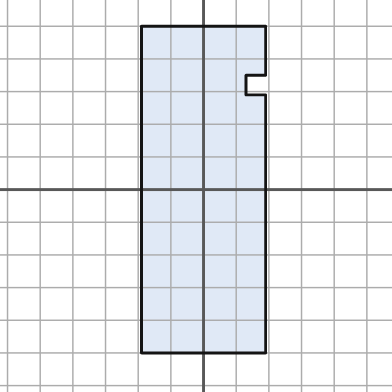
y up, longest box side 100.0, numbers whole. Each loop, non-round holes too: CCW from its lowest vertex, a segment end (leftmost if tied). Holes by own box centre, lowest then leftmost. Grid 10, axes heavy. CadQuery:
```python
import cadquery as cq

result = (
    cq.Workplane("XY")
    .moveTo(-19.0, -50.0)
    .lineTo(19.0, -50.0)
    .lineTo(19.0, 29.0)
    .lineTo(13.0, 29.0)
    .lineTo(13.0, 35.0)
    .lineTo(19.0, 35.0)
    .lineTo(19.0, 50.0)
    .lineTo(-19.0, 50.0)
    .close()
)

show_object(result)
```